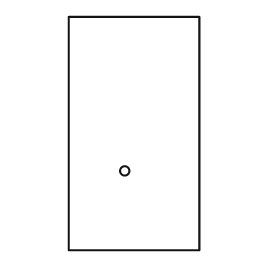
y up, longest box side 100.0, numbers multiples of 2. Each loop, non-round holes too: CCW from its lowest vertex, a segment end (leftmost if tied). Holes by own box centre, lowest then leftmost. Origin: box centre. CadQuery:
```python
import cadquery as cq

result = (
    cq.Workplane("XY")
    .moveTo(-28.0, -50.0)
    .lineTo(28.0, -50.0)
    .lineTo(28.0, 50.0)
    .lineTo(-28.0, 50.0)
    .close()
    .moveTo(-4.0, -16.0)
    .circle(2.0)
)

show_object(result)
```